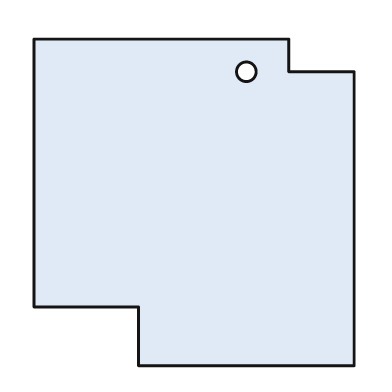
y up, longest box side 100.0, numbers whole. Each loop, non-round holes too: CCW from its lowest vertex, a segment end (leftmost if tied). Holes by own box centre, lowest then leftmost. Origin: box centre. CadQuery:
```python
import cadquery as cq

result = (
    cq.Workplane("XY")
    .moveTo(-17.0, -50.0)
    .lineTo(49.0, -50.0)
    .lineTo(49.0, 40.0)
    .lineTo(29.0, 40.0)
    .lineTo(29.0, 50.0)
    .lineTo(-49.0, 50.0)
    .lineTo(-49.0, -32.0)
    .lineTo(-17.0, -32.0)
    .close()
    .moveTo(16.0, 40.0)
    .circle(3.0)
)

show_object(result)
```